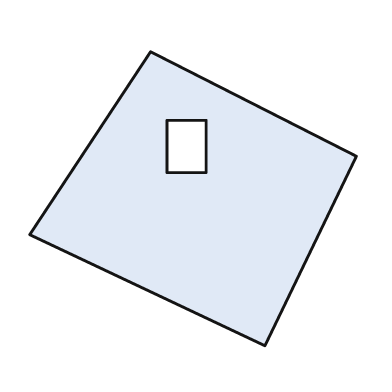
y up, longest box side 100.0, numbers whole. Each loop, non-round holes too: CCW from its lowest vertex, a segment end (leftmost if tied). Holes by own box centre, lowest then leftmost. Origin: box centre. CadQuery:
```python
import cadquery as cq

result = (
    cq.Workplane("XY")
    .moveTo(22.0, -45.0)
    .lineTo(50.0, 13.0)
    .lineTo(-13.0, 45.0)
    .lineTo(-50.0, -11.0)
    .close()
    .moveTo(-8.0, 8.0)
    .lineTo(4.0, 8.0)
    .lineTo(4.0, 24.0)
    .lineTo(-8.0, 24.0)
    .close()
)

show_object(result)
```